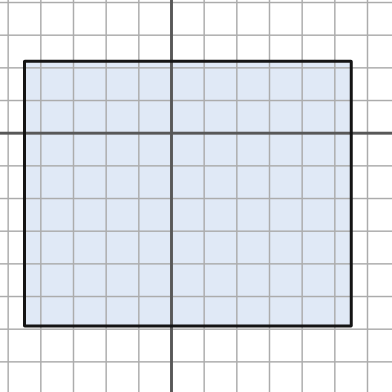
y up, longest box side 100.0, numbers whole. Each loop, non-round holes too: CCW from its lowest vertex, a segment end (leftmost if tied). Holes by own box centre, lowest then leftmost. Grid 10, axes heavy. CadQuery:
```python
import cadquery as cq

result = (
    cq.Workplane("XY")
    .moveTo(-45.0, -59.0)
    .lineTo(55.0, -59.0)
    .lineTo(55.0, 22.0)
    .lineTo(-45.0, 22.0)
    .close()
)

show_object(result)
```